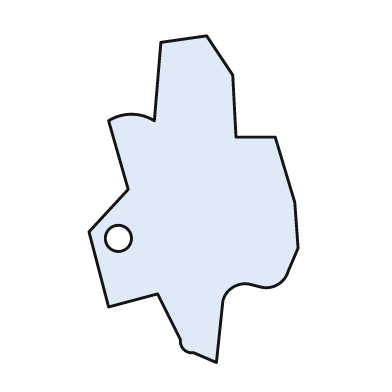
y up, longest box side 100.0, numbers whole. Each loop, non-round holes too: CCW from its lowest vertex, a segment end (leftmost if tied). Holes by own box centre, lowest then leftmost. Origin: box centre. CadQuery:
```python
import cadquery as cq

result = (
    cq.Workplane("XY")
    .moveTo(7.0, -50.0)
    .lineTo(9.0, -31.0)
    .threePointArc((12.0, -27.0), (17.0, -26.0))
    .lineTo(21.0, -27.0)
    .threePointArc((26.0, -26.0), (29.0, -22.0))
    .lineTo(32.0, -15.0)
    .lineTo(31.0, -1.0)
    .lineTo(25.0, 19.0)
    .lineTo(13.0, 19.0)
    .lineTo(12.0, 38.0)
    .lineTo(4.0, 50.0)
    .lineTo(-10.0, 48.0)
    .lineTo(-12.0, 24.0)
    .threePointArc((-19.0, 26.0), (-26.0, 24.0))
    .lineTo(-20.0, 3.0)
    .lineTo(-32.0, -10.0)
    .lineTo(-26.0, -33.0)
    .lineTo(-11.0, -29.0)
    .lineTo(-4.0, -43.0)
    .threePointArc((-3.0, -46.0), (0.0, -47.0))
    .close()
    .moveTo(-23.0, -12.0)
    .circle(4.0)
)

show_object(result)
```